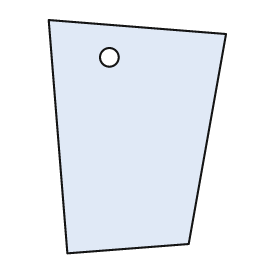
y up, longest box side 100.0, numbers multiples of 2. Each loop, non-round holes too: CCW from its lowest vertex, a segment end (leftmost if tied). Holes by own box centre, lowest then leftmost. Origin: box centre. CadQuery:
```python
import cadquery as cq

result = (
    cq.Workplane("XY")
    .moveTo(-30.0, -50.0)
    .lineTo(22.0, -46.0)
    .lineTo(38.0, 44.0)
    .lineTo(-38.0, 50.0)
    .close()
    .moveTo(-12.0, 34.0)
    .circle(4.0)
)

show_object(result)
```